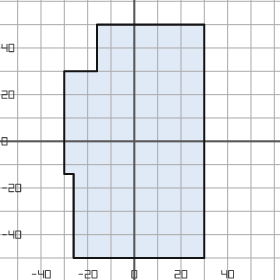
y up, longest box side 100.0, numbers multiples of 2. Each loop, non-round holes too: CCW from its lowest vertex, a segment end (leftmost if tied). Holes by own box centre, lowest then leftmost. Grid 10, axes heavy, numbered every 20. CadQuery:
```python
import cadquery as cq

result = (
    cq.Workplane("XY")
    .moveTo(-26.0, -50.0)
    .lineTo(30.0, -50.0)
    .lineTo(30.0, 50.0)
    .lineTo(-16.0, 50.0)
    .lineTo(-16.0, 30.0)
    .lineTo(-30.0, 30.0)
    .lineTo(-30.0, -14.0)
    .lineTo(-26.0, -14.0)
    .close()
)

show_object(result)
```